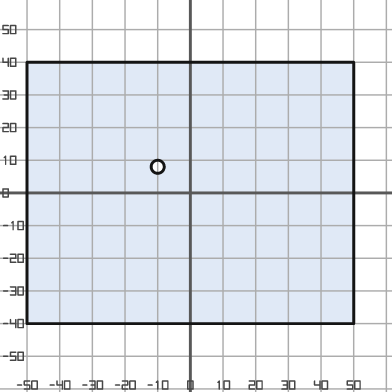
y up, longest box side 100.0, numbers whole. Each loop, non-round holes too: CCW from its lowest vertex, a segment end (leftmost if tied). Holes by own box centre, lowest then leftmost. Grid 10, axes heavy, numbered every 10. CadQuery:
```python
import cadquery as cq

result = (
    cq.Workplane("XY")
    .moveTo(-50.0, -40.0)
    .lineTo(50.0, -40.0)
    .lineTo(50.0, 40.0)
    .lineTo(-50.0, 40.0)
    .close()
    .moveTo(-10.0, 8.0)
    .circle(2.0)
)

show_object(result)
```